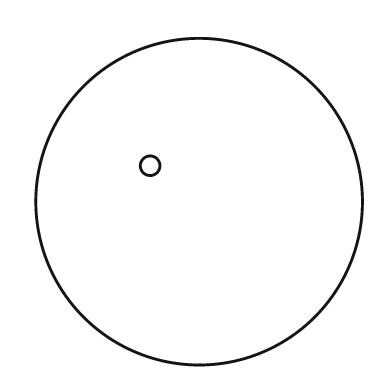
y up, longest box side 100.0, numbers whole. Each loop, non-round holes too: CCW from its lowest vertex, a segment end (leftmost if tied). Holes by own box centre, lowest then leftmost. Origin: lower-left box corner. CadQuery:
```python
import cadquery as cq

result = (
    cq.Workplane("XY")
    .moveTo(50.0, 50.0)
    .circle(50.0)
    .moveTo(35.0, 61.0)
    .circle(3.0)
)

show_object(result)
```